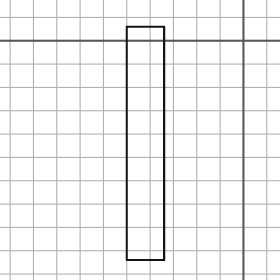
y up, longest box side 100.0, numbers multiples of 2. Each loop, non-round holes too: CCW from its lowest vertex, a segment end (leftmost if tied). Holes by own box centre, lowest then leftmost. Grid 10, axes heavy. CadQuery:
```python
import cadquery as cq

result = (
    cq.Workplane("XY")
    .moveTo(-50.0, -94.0)
    .lineTo(-34.0, -94.0)
    .lineTo(-34.0, 6.0)
    .lineTo(-50.0, 6.0)
    .close()
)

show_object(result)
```